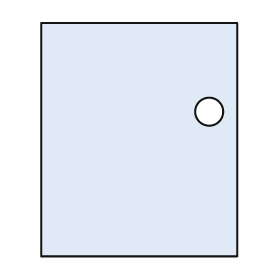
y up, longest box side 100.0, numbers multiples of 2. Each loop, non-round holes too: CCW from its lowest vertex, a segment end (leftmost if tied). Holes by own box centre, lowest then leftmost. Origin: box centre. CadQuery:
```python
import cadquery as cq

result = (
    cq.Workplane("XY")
    .moveTo(-42.0, -50.0)
    .lineTo(42.0, -50.0)
    .lineTo(42.0, 50.0)
    .lineTo(-42.0, 50.0)
    .close()
    .moveTo(30.0, 12.0)
    .circle(6.0)
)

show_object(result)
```